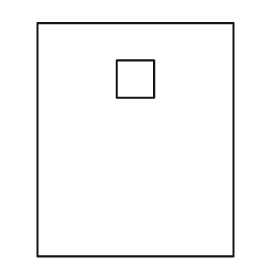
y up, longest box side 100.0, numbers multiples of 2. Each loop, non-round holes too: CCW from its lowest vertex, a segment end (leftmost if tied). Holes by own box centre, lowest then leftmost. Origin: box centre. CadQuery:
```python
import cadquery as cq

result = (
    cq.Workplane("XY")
    .moveTo(-42.0, -50.0)
    .lineTo(42.0, -50.0)
    .lineTo(42.0, 50.0)
    .lineTo(-42.0, 50.0)
    .close()
    .moveTo(-8.0, 18.0)
    .lineTo(8.0, 18.0)
    .lineTo(8.0, 34.0)
    .lineTo(-8.0, 34.0)
    .close()
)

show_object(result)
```